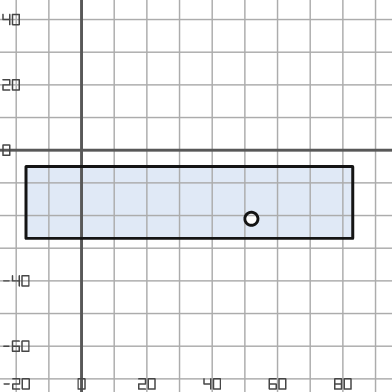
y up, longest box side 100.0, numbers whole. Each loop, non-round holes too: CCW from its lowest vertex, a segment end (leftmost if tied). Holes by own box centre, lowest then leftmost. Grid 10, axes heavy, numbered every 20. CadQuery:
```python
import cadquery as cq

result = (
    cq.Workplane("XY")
    .moveTo(-17.0, -27.0)
    .lineTo(83.0, -27.0)
    .lineTo(83.0, -5.0)
    .lineTo(-17.0, -5.0)
    .close()
    .moveTo(52.0, -21.0)
    .circle(2.0)
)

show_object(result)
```